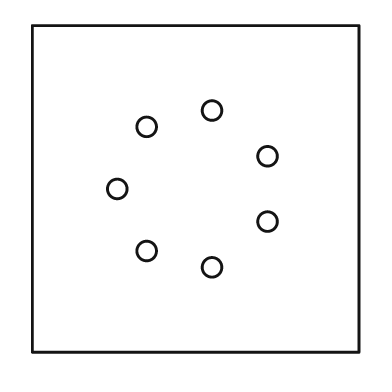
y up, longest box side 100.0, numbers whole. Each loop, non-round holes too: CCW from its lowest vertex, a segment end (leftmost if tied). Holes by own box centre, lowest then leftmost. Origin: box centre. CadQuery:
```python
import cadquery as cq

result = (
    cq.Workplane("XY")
    .moveTo(-50.0, -50.0)
    .lineTo(50.0, -50.0)
    .lineTo(50.0, 50.0)
    .lineTo(-50.0, 50.0)
    .close()
    .moveTo(5.0, -24.0)
    .circle(3.0)
    .moveTo(-15.0, -19.0)
    .circle(3.0)
    .moveTo(22.0, -10.0)
    .circle(3.0)
    .moveTo(-24.0, 0.0)
    .circle(3.0)
    .moveTo(22.0, 10.0)
    .circle(3.0)
    .moveTo(-15.0, 19.0)
    .circle(3.0)
    .moveTo(5.0, 24.0)
    .circle(3.0)
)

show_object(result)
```